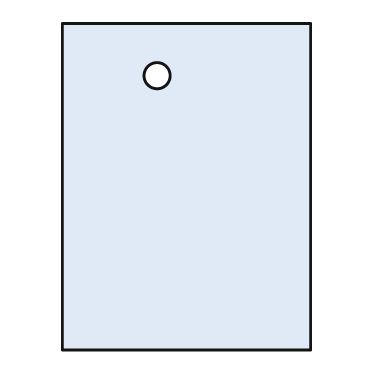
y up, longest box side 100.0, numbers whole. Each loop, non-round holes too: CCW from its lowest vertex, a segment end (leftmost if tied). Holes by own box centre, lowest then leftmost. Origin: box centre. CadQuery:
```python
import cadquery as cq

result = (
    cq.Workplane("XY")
    .moveTo(-38.0, -50.0)
    .lineTo(38.0, -50.0)
    .lineTo(38.0, 50.0)
    .lineTo(-38.0, 50.0)
    .close()
    .moveTo(-9.0, 34.0)
    .circle(4.0)
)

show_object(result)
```